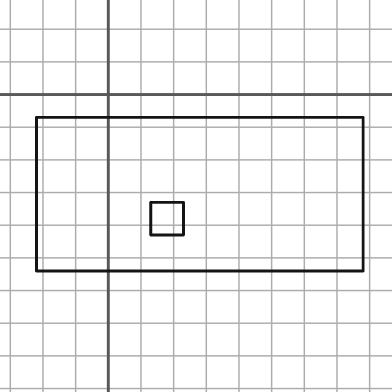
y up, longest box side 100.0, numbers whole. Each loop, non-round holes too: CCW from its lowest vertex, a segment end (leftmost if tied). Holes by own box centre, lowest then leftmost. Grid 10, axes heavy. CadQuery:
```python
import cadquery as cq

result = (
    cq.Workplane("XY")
    .moveTo(-22.0, -54.0)
    .lineTo(78.0, -54.0)
    .lineTo(78.0, -7.0)
    .lineTo(-22.0, -7.0)
    .close()
    .moveTo(13.0, -43.0)
    .lineTo(23.0, -43.0)
    .lineTo(23.0, -33.0)
    .lineTo(13.0, -33.0)
    .close()
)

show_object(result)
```